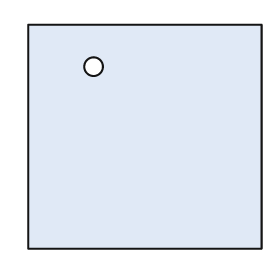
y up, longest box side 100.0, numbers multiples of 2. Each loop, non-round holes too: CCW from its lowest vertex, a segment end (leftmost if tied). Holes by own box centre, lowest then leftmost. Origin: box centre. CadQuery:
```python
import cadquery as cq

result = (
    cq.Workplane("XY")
    .moveTo(-50.0, -48.0)
    .lineTo(50.0, -48.0)
    .lineTo(50.0, 48.0)
    .lineTo(-50.0, 48.0)
    .close()
    .moveTo(-22.0, 30.0)
    .circle(4.0)
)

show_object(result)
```